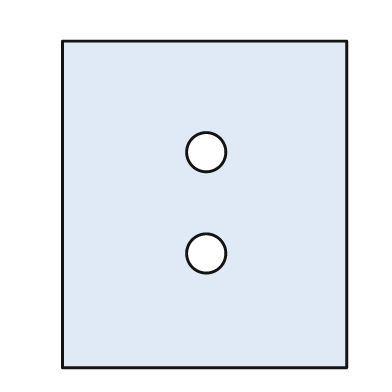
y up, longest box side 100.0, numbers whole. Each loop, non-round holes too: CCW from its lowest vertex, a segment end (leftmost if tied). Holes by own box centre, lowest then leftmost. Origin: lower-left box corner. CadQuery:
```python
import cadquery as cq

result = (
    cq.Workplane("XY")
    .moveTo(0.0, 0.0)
    .lineTo(87.0, 0.0)
    .lineTo(87.0, 100.0)
    .lineTo(0.0, 100.0)
    .close()
    .moveTo(44.0, 35.0)
    .circle(6.0)
    .moveTo(44.0, 66.0)
    .circle(6.0)
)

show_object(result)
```